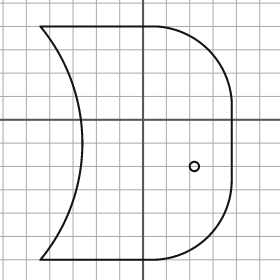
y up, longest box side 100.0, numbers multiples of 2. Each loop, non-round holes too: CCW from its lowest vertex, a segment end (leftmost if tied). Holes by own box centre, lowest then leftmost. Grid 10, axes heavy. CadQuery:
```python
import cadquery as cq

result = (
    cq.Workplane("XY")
    .moveTo(-44.0, -60.0)
    .lineTo(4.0, -60.0)
    .threePointArc((28.0, -50.0), (38.0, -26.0))
    .lineTo(38.0, 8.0)
    .threePointArc((28.0, 30.0), (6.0, 40.0))
    .lineTo(-44.0, 40.0)
    .threePointArc((-26.0, -10.0), (-44.0, -60.0))
    .close()
    .moveTo(22.0, -20.0)
    .circle(2.0)
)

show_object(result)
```